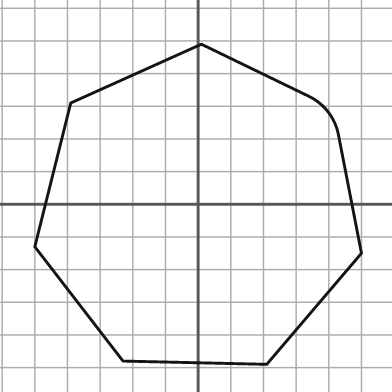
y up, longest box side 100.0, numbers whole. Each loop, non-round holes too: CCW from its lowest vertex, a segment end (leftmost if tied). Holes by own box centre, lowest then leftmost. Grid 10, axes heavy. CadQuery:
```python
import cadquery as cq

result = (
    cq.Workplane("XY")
    .moveTo(21.0, -49.0)
    .lineTo(50.0, -15.0)
    .lineTo(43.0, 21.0)
    .threePointArc((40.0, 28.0), (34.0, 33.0))
    .lineTo(1.0, 49.0)
    .lineTo(-39.0, 31.0)
    .lineTo(-50.0, -13.0)
    .lineTo(-23.0, -48.0)
    .close()
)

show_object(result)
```